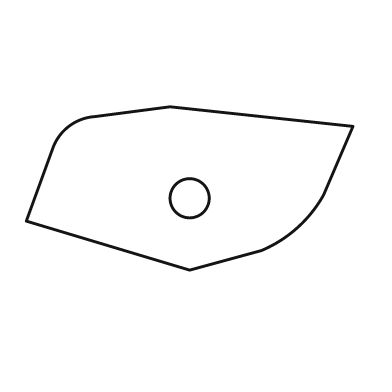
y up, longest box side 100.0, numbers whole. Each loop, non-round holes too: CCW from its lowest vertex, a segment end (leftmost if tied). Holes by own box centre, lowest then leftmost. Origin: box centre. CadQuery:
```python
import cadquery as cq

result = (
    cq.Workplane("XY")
    .moveTo(0.0, -25.0)
    .lineTo(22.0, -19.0)
    .threePointArc((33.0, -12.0), (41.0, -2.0))
    .lineTo(50.0, 19.0)
    .lineTo(-6.0, 25.0)
    .lineTo(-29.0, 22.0)
    .threePointArc((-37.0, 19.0), (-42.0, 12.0))
    .lineTo(-50.0, -10.0)
    .close()
    .moveTo(0.0, -3.0)
    .circle(6.0)
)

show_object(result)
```